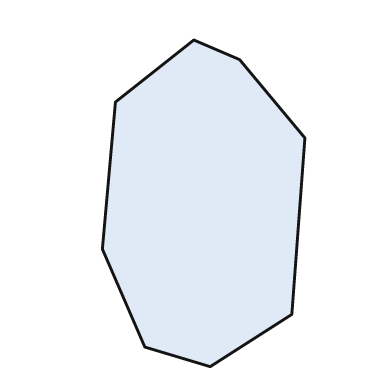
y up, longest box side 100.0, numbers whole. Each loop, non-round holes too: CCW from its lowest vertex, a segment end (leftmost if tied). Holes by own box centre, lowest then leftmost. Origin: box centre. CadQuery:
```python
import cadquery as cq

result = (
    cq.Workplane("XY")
    .moveTo(2.0, -50.0)
    .lineTo(27.0, -34.0)
    .lineTo(31.0, 20.0)
    .lineTo(11.0, 44.0)
    .lineTo(-3.0, 50.0)
    .lineTo(-27.0, 31.0)
    .lineTo(-31.0, -14.0)
    .lineTo(-18.0, -44.0)
    .close()
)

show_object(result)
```